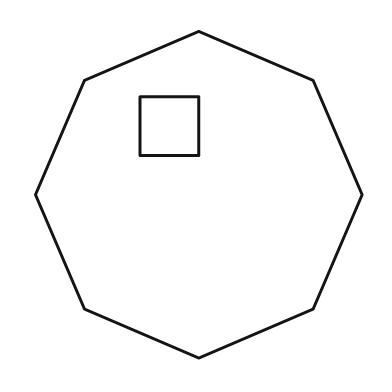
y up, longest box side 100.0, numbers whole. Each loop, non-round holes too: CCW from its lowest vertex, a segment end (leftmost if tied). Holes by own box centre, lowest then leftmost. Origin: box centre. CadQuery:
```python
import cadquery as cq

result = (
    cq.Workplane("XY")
    .moveTo(0.0, -50.0)
    .lineTo(35.0, -35.0)
    .lineTo(50.0, 0.0)
    .lineTo(35.0, 35.0)
    .lineTo(0.0, 50.0)
    .lineTo(-35.0, 35.0)
    .lineTo(-50.0, 0.0)
    .lineTo(-35.0, -35.0)
    .close()
    .moveTo(-18.0, 12.0)
    .lineTo(0.0, 12.0)
    .lineTo(0.0, 30.0)
    .lineTo(-18.0, 30.0)
    .close()
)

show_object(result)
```